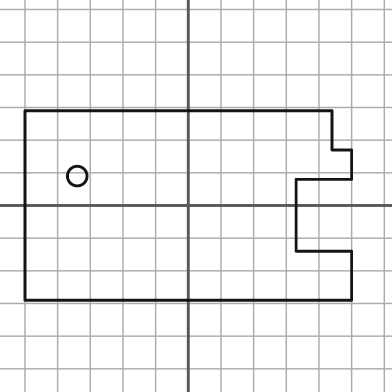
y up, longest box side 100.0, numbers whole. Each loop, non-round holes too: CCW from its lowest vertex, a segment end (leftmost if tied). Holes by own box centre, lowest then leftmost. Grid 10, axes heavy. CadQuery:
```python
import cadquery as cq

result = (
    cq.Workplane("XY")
    .moveTo(-50.0, -29.0)
    .lineTo(50.0, -29.0)
    .lineTo(50.0, -14.0)
    .lineTo(33.0, -14.0)
    .lineTo(33.0, 8.0)
    .lineTo(50.0, 8.0)
    .lineTo(50.0, 17.0)
    .lineTo(44.0, 17.0)
    .lineTo(44.0, 29.0)
    .lineTo(-50.0, 29.0)
    .close()
    .moveTo(-34.0, 9.0)
    .circle(3.0)
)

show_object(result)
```